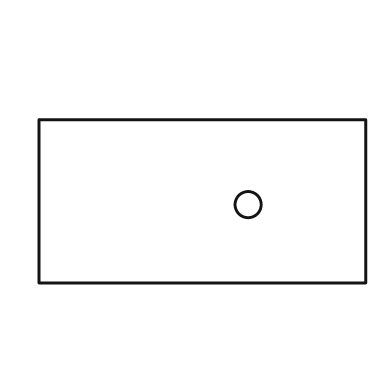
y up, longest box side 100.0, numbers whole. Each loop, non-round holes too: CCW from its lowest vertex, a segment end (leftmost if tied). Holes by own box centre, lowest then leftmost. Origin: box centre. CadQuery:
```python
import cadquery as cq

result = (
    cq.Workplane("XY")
    .moveTo(-50.0, -25.0)
    .lineTo(50.0, -25.0)
    .lineTo(50.0, 25.0)
    .lineTo(-50.0, 25.0)
    .close()
    .moveTo(14.0, -1.0)
    .circle(4.0)
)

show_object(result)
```